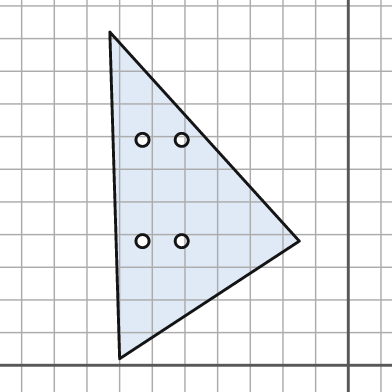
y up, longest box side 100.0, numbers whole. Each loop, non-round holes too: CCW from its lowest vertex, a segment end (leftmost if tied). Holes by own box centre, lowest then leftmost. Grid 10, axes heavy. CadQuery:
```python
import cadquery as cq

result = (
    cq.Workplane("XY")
    .moveTo(-70.0, 2.0)
    .lineTo(-15.0, 38.0)
    .lineTo(-73.0, 102.0)
    .close()
    .moveTo(-63.0, 38.0)
    .circle(2.0)
    .moveTo(-51.0, 38.0)
    .circle(2.0)
    .moveTo(-63.0, 69.0)
    .circle(2.0)
    .moveTo(-51.0, 69.0)
    .circle(2.0)
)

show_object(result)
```